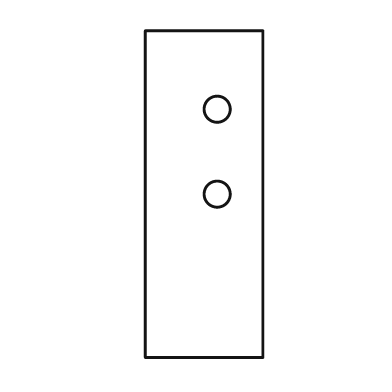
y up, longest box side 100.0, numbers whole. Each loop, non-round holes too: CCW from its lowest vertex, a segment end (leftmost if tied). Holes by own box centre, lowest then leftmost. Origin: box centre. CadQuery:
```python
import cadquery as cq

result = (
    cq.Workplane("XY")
    .moveTo(-18.0, -50.0)
    .lineTo(18.0, -50.0)
    .lineTo(18.0, 50.0)
    .lineTo(-18.0, 50.0)
    .close()
    .moveTo(4.0, 0.0)
    .circle(4.0)
    .moveTo(4.0, 26.0)
    .circle(4.0)
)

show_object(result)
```